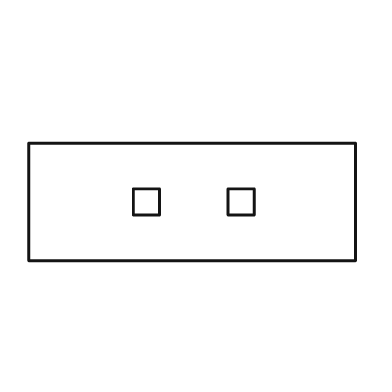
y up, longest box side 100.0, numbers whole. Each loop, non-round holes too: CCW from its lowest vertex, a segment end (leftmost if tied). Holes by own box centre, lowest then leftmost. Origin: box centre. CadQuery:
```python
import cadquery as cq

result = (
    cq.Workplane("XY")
    .moveTo(-50.0, -18.0)
    .lineTo(50.0, -18.0)
    .lineTo(50.0, 18.0)
    .lineTo(-50.0, 18.0)
    .close()
    .moveTo(-18.0, -4.0)
    .lineTo(-10.0, -4.0)
    .lineTo(-10.0, 4.0)
    .lineTo(-18.0, 4.0)
    .close()
    .moveTo(11.0, -4.0)
    .lineTo(19.0, -4.0)
    .lineTo(19.0, 4.0)
    .lineTo(11.0, 4.0)
    .close()
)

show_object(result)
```